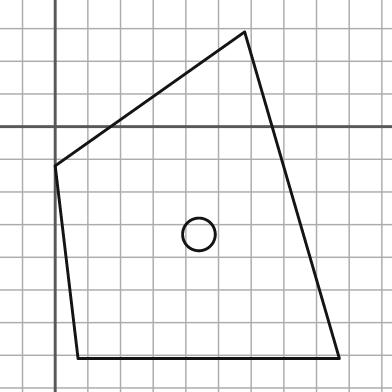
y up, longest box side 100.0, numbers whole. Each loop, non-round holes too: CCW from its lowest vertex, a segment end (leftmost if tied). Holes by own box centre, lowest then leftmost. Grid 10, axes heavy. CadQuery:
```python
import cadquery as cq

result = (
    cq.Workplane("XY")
    .moveTo(7.0, -71.0)
    .lineTo(87.0, -71.0)
    .lineTo(58.0, 29.0)
    .lineTo(0.0, -12.0)
    .close()
    .moveTo(44.0, -33.0)
    .circle(5.0)
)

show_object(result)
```